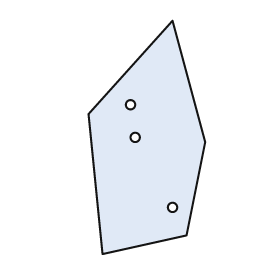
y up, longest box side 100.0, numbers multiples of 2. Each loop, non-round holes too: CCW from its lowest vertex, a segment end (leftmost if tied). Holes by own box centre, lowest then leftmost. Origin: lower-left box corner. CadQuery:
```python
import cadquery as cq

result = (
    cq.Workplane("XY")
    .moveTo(6.0, 0.0)
    .lineTo(42.0, 8.0)
    .lineTo(50.0, 48.0)
    .lineTo(36.0, 100.0)
    .lineTo(0.0, 60.0)
    .close()
    .moveTo(36.0, 20.0)
    .circle(2.0)
    .moveTo(20.0, 50.0)
    .circle(2.0)
    .moveTo(18.0, 64.0)
    .circle(2.0)
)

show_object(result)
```